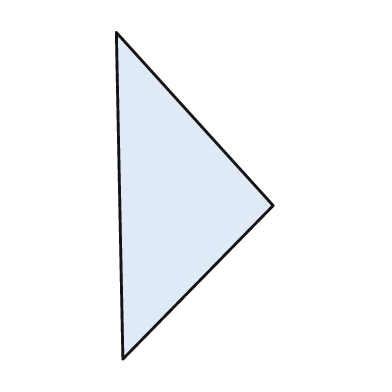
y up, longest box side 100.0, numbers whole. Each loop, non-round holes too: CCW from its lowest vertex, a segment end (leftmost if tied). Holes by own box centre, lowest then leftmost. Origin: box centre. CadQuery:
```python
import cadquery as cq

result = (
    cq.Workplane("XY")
    .moveTo(-22.0, -50.0)
    .lineTo(24.0, -3.0)
    .lineTo(-24.0, 50.0)
    .close()
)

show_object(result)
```